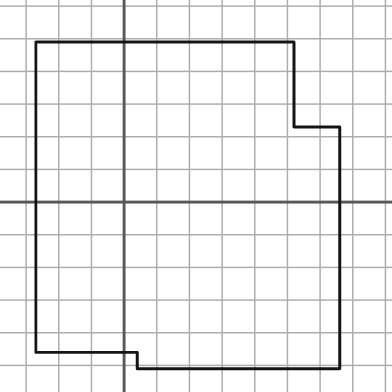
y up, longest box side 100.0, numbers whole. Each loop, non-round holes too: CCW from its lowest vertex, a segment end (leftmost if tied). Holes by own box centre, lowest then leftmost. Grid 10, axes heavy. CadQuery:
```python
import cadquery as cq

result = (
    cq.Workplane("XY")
    .moveTo(4.0, -51.0)
    .lineTo(66.0, -51.0)
    .lineTo(66.0, 23.0)
    .lineTo(52.0, 23.0)
    .lineTo(52.0, 49.0)
    .lineTo(-27.0, 49.0)
    .lineTo(-27.0, -46.0)
    .lineTo(4.0, -46.0)
    .close()
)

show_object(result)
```